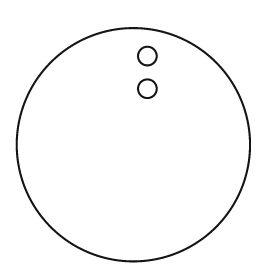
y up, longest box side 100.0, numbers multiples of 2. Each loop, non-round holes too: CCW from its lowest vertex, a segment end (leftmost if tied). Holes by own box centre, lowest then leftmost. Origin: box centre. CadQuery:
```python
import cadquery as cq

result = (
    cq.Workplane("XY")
    .moveTo(0.0, 0.0)
    .circle(50.0)
    .moveTo(6.0, 24.0)
    .circle(4.0)
    .moveTo(6.0, 38.0)
    .circle(4.0)
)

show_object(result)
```